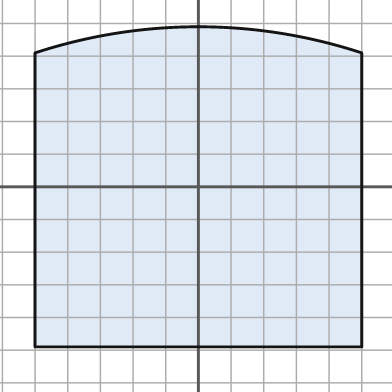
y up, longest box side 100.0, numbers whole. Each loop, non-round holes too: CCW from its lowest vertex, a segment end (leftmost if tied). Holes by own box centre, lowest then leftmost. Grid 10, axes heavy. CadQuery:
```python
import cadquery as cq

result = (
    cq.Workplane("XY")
    .moveTo(-50.0, -49.0)
    .lineTo(50.0, -49.0)
    .lineTo(50.0, 41.0)
    .threePointArc((0.0, 49.0), (-50.0, 41.0))
    .close()
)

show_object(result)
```